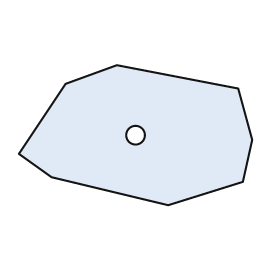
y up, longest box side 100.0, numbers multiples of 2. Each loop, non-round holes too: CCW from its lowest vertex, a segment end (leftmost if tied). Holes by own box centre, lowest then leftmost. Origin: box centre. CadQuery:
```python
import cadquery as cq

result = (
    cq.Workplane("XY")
    .moveTo(14.0, -30.0)
    .lineTo(46.0, -20.0)
    .lineTo(50.0, -2.0)
    .lineTo(44.0, 20.0)
    .lineTo(-8.0, 30.0)
    .lineTo(-30.0, 22.0)
    .lineTo(-50.0, -8.0)
    .lineTo(-36.0, -18.0)
    .close()
    .moveTo(0.0, 0.0)
    .circle(4.0)
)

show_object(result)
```